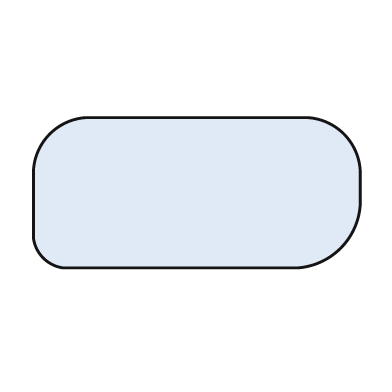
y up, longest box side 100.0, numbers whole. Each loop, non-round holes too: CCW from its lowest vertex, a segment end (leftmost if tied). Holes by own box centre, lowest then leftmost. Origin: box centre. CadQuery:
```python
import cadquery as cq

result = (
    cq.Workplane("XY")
    .moveTo(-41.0, -23.0)
    .lineTo(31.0, -23.0)
    .threePointArc((44.0, -17.0), (50.0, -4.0))
    .lineTo(50.0, 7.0)
    .threePointArc((45.0, 18.0), (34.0, 23.0))
    .lineTo(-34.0, 23.0)
    .threePointArc((-45.0, 18.0), (-50.0, 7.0))
    .lineTo(-50.0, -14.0)
    .threePointArc((-47.0, -20.0), (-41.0, -23.0))
    .close()
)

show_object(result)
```